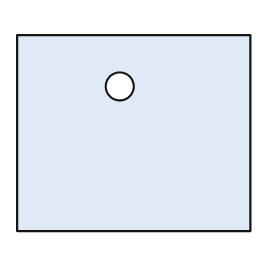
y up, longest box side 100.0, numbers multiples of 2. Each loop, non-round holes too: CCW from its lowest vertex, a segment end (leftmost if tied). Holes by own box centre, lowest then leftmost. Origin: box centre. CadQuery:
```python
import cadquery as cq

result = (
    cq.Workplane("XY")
    .moveTo(-50.0, -42.0)
    .lineTo(50.0, -42.0)
    .lineTo(50.0, 42.0)
    .lineTo(-50.0, 42.0)
    .close()
    .moveTo(-6.0, 20.0)
    .circle(6.0)
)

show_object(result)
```